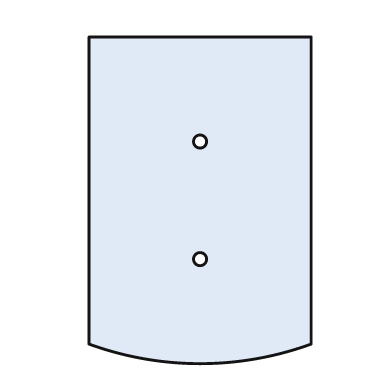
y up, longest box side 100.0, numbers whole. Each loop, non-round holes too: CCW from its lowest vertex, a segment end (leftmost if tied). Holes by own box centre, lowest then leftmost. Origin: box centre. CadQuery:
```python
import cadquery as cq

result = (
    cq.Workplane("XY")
    .moveTo(-34.0, -44.0)
    .threePointArc((0.0, -50.0), (34.0, -44.0))
    .lineTo(34.0, 50.0)
    .lineTo(-34.0, 50.0)
    .close()
    .moveTo(0.0, -18.0)
    .circle(2.0)
    .moveTo(0.0, 18.0)
    .circle(2.0)
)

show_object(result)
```